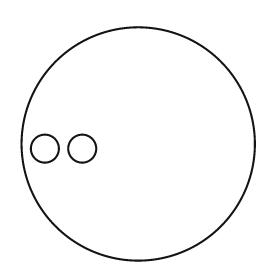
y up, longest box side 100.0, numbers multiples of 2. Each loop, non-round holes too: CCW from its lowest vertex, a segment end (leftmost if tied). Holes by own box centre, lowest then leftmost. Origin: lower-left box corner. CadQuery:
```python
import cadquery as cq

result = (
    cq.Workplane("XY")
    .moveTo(50.0, 50.0)
    .circle(50.0)
    .moveTo(10.0, 48.0)
    .circle(6.0)
    .moveTo(26.0, 48.0)
    .circle(6.0)
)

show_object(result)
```